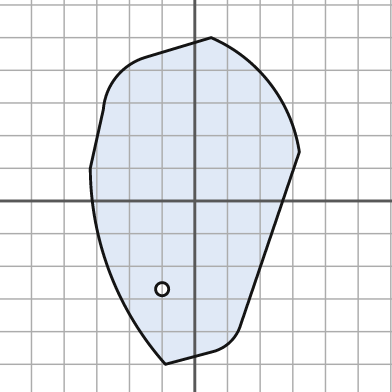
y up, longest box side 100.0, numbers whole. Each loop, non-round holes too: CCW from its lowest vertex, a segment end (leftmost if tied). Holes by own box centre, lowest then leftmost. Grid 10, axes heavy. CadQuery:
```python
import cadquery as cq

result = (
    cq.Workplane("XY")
    .moveTo(-9.0, -50.0)
    .lineTo(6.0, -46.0)
    .threePointArc((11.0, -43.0), (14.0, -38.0))
    .lineTo(32.0, 15.0)
    .threePointArc((23.0, 36.0), (5.0, 50.0))
    .lineTo(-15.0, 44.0)
    .threePointArc((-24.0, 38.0), (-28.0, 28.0))
    .lineTo(-32.0, 10.0)
    .threePointArc((-26.0, -22.0), (-9.0, -50.0))
    .close()
    .moveTo(-10.0, -27.0)
    .circle(2.0)
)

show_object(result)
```